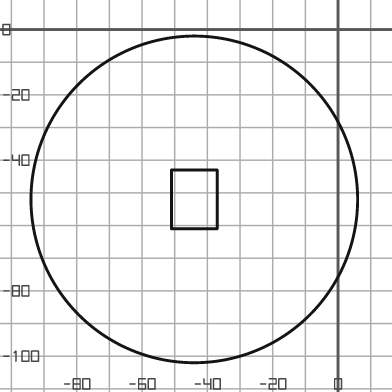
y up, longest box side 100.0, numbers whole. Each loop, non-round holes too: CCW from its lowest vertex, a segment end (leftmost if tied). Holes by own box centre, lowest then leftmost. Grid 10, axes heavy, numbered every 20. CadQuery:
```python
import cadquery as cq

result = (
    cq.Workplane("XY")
    .moveTo(-44.0, -52.0)
    .circle(50.0)
    .moveTo(-51.0, -61.0)
    .lineTo(-37.0, -61.0)
    .lineTo(-37.0, -43.0)
    .lineTo(-51.0, -43.0)
    .close()
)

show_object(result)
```